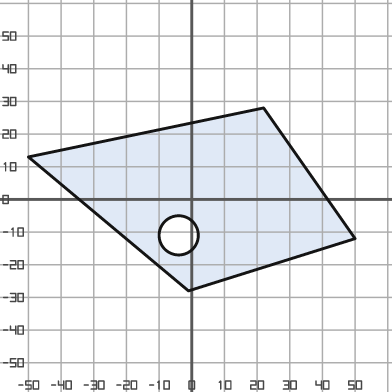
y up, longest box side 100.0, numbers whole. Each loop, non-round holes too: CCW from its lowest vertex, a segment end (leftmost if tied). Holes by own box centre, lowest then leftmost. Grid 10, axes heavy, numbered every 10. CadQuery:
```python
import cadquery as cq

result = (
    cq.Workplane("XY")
    .moveTo(-1.0, -28.0)
    .lineTo(50.0, -12.0)
    .lineTo(22.0, 28.0)
    .lineTo(-50.0, 13.0)
    .close()
    .moveTo(-4.0, -11.0)
    .circle(6.0)
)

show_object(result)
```